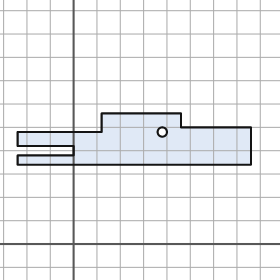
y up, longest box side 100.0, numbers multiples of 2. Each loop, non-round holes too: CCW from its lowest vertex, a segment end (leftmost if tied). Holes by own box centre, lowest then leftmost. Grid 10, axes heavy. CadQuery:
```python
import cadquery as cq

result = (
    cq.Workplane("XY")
    .moveTo(-24.0, 34.0)
    .lineTo(76.0, 34.0)
    .lineTo(76.0, 50.0)
    .lineTo(46.0, 50.0)
    .lineTo(46.0, 56.0)
    .lineTo(12.0, 56.0)
    .lineTo(12.0, 48.0)
    .lineTo(-24.0, 48.0)
    .lineTo(-24.0, 42.0)
    .lineTo(0.0, 42.0)
    .lineTo(0.0, 38.0)
    .lineTo(-24.0, 38.0)
    .close()
    .moveTo(38.0, 48.0)
    .circle(2.0)
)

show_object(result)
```